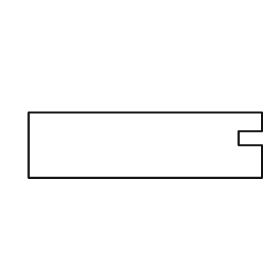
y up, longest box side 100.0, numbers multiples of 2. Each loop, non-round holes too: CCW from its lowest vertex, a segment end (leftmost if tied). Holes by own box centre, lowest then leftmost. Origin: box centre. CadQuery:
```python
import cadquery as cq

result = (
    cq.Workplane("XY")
    .moveTo(-50.0, -14.0)
    .lineTo(50.0, -14.0)
    .lineTo(50.0, 0.0)
    .lineTo(40.0, 0.0)
    .lineTo(40.0, 6.0)
    .lineTo(50.0, 6.0)
    .lineTo(50.0, 14.0)
    .lineTo(-50.0, 14.0)
    .close()
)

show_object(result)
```